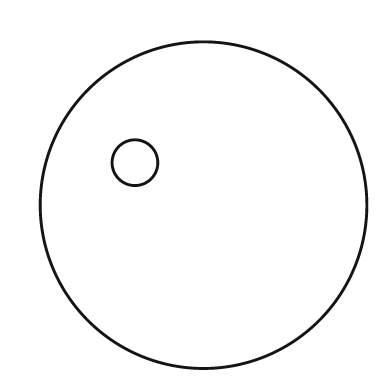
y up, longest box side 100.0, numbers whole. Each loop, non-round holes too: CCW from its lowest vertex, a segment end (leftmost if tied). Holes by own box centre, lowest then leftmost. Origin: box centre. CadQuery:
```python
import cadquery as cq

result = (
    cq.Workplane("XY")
    .moveTo(0.0, 0.0)
    .circle(50.0)
    .moveTo(-21.0, 13.0)
    .circle(7.0)
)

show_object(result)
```